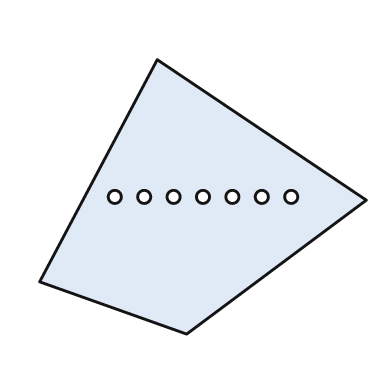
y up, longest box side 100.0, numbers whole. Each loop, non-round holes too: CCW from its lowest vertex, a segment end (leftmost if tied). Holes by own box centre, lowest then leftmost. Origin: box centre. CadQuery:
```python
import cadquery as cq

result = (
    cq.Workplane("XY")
    .moveTo(-5.0, -42.0)
    .lineTo(50.0, -1.0)
    .lineTo(-14.0, 42.0)
    .lineTo(-50.0, -26.0)
    .close()
    .moveTo(-27.0, 0.0)
    .circle(2.0)
    .moveTo(-18.0, 0.0)
    .circle(2.0)
    .moveTo(-9.0, 0.0)
    .circle(2.0)
    .moveTo(0.0, 0.0)
    .circle(2.0)
    .moveTo(9.0, 0.0)
    .circle(2.0)
    .moveTo(18.0, 0.0)
    .circle(2.0)
    .moveTo(27.0, 0.0)
    .circle(2.0)
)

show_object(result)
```